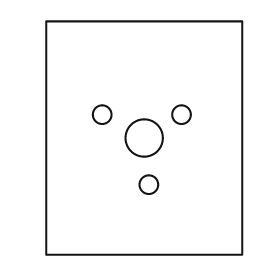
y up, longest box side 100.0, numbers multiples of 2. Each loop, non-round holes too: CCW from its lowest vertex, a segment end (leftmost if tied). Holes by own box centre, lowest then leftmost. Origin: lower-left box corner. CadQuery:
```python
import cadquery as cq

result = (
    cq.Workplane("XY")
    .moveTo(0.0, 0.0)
    .lineTo(84.0, 0.0)
    .lineTo(84.0, 100.0)
    .lineTo(0.0, 100.0)
    .close()
    .moveTo(44.0, 30.0)
    .circle(4.0)
    .moveTo(42.0, 50.0)
    .circle(8.0)
    .moveTo(24.0, 60.0)
    .circle(4.0)
    .moveTo(58.0, 60.0)
    .circle(4.0)
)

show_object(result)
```